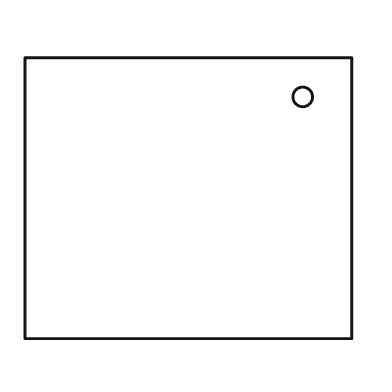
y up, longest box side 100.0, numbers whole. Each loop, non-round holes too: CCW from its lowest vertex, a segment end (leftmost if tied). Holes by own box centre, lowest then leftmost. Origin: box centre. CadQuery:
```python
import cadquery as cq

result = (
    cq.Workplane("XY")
    .moveTo(-50.0, -43.0)
    .lineTo(50.0, -43.0)
    .lineTo(50.0, 43.0)
    .lineTo(-50.0, 43.0)
    .close()
    .moveTo(35.0, 31.0)
    .circle(3.0)
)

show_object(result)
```